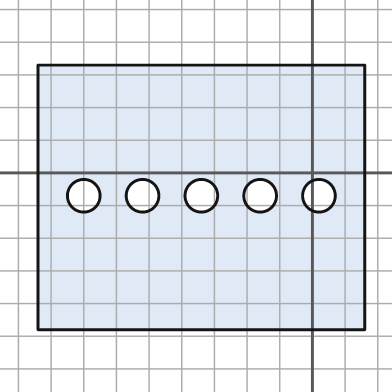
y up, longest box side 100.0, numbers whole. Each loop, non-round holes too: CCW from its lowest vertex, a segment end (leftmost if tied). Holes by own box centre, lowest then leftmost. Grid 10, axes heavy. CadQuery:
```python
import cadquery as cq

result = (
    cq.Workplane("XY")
    .moveTo(-84.0, -48.0)
    .lineTo(16.0, -48.0)
    .lineTo(16.0, 33.0)
    .lineTo(-84.0, 33.0)
    .close()
    .moveTo(-70.0, -7.0)
    .circle(5.0)
    .moveTo(-52.0, -7.0)
    .circle(5.0)
    .moveTo(-34.0, -7.0)
    .circle(5.0)
    .moveTo(-16.0, -7.0)
    .circle(5.0)
    .moveTo(2.0, -7.0)
    .circle(5.0)
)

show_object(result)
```